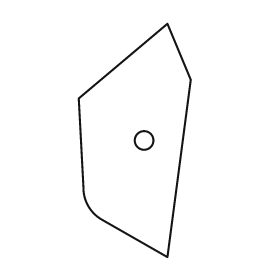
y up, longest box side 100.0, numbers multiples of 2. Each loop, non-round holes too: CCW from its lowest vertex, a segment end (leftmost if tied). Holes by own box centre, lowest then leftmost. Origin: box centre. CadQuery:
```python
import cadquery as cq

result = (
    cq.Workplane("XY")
    .moveTo(14.0, -50.0)
    .lineTo(24.0, 26.0)
    .lineTo(14.0, 50.0)
    .lineTo(-24.0, 18.0)
    .lineTo(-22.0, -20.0)
    .threePointArc((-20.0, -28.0), (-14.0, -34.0))
    .close()
    .moveTo(4.0, 0.0)
    .circle(4.0)
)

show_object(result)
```